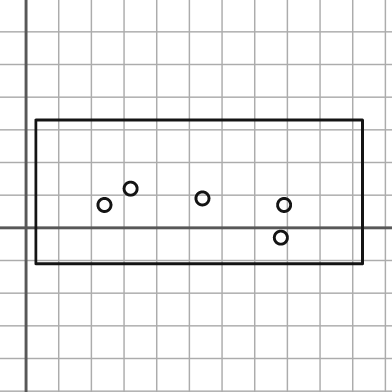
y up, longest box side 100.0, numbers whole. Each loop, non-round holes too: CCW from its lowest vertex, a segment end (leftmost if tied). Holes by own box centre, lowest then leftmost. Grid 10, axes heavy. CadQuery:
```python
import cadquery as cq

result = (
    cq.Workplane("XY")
    .moveTo(3.0, -11.0)
    .lineTo(103.0, -11.0)
    .lineTo(103.0, 33.0)
    .lineTo(3.0, 33.0)
    .close()
    .moveTo(78.0, -3.0)
    .circle(2.0)
    .moveTo(24.0, 7.0)
    .circle(2.0)
    .moveTo(79.0, 7.0)
    .circle(2.0)
    .moveTo(54.0, 9.0)
    .circle(2.0)
    .moveTo(32.0, 12.0)
    .circle(2.0)
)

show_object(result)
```